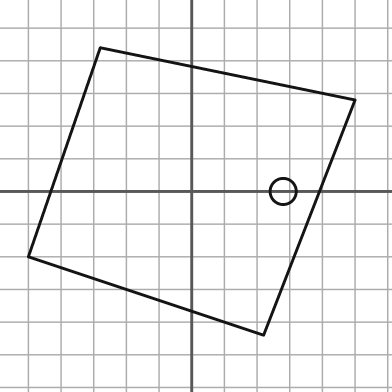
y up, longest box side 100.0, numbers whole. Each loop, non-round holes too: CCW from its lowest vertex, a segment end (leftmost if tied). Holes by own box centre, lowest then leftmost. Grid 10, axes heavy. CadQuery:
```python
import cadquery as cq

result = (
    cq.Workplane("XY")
    .moveTo(22.0, -44.0)
    .lineTo(50.0, 28.0)
    .lineTo(-28.0, 44.0)
    .lineTo(-50.0, -20.0)
    .close()
    .moveTo(28.0, 0.0)
    .circle(4.0)
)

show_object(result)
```